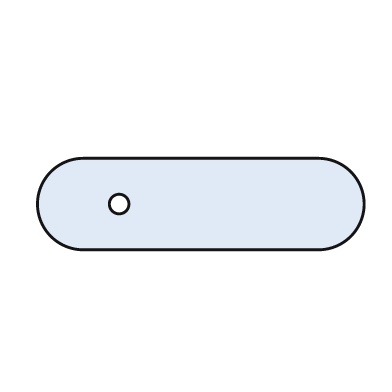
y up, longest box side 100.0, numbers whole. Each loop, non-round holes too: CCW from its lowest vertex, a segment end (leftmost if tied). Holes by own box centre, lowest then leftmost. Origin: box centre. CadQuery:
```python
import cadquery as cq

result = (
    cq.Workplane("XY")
    .moveTo(-36.0, -14.0)
    .lineTo(36.0, -14.0)
    .threePointArc((50.0, 0.0), (36.0, 14.0))
    .lineTo(-36.0, 14.0)
    .threePointArc((-50.0, 0.0), (-36.0, -14.0))
    .close()
    .moveTo(-25.0, 0.0)
    .circle(3.0)
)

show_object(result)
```